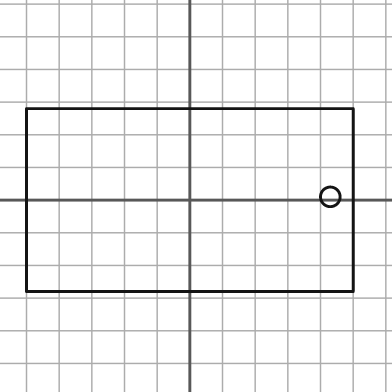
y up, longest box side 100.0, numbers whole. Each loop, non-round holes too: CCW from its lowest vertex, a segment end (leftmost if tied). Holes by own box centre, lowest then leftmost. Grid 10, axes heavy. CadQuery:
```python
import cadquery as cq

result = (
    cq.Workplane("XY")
    .moveTo(-50.0, -28.0)
    .lineTo(50.0, -28.0)
    .lineTo(50.0, 28.0)
    .lineTo(-50.0, 28.0)
    .close()
    .moveTo(43.0, 1.0)
    .circle(3.0)
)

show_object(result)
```